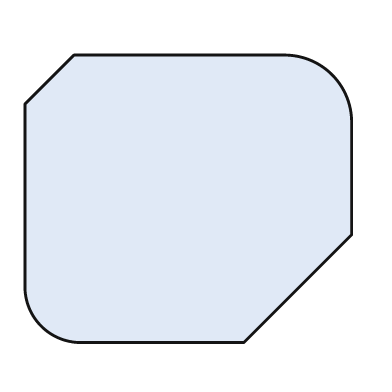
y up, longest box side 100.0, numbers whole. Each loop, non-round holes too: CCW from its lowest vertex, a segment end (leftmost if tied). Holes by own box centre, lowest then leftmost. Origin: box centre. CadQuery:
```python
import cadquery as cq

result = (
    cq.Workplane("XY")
    .moveTo(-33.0, -44.0)
    .lineTo(17.0, -44.0)
    .lineTo(50.0, -11.0)
    .lineTo(50.0, 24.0)
    .threePointArc((44.0, 38.0), (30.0, 44.0))
    .lineTo(-35.0, 44.0)
    .lineTo(-50.0, 29.0)
    .lineTo(-50.0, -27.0)
    .threePointArc((-45.0, -39.0), (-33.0, -44.0))
    .close()
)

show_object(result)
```